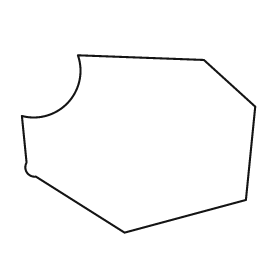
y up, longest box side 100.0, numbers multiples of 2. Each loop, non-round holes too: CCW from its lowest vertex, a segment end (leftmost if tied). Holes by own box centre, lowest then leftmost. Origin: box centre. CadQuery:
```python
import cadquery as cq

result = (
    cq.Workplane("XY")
    .moveTo(-6.0, -38.0)
    .lineTo(46.0, -24.0)
    .lineTo(50.0, 16.0)
    .lineTo(28.0, 36.0)
    .lineTo(-26.0, 38.0)
    .threePointArc((-30.0, 18.0), (-50.0, 12.0))
    .lineTo(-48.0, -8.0)
    .threePointArc((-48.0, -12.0), (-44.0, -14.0))
    .close()
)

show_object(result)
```